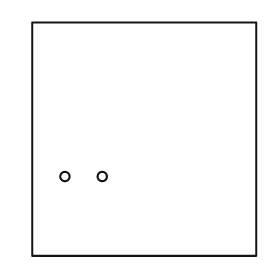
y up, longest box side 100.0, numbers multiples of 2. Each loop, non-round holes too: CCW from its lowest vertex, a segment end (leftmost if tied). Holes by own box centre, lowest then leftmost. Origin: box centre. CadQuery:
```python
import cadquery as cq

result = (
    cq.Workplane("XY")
    .moveTo(-48.0, -50.0)
    .lineTo(48.0, -50.0)
    .lineTo(48.0, 50.0)
    .lineTo(-48.0, 50.0)
    .close()
    .moveTo(-34.0, -16.0)
    .circle(2.0)
    .moveTo(-18.0, -16.0)
    .circle(2.0)
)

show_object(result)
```